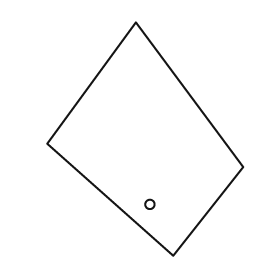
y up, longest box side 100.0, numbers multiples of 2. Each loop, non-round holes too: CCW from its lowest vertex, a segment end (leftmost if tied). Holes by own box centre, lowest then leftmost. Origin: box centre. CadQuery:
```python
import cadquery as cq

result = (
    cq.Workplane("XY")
    .moveTo(12.0, -50.0)
    .lineTo(42.0, -12.0)
    .lineTo(-4.0, 50.0)
    .lineTo(-42.0, -2.0)
    .close()
    .moveTo(2.0, -28.0)
    .circle(2.0)
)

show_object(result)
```